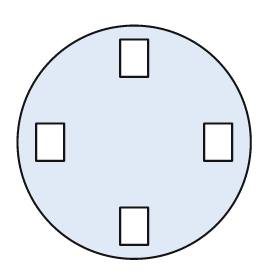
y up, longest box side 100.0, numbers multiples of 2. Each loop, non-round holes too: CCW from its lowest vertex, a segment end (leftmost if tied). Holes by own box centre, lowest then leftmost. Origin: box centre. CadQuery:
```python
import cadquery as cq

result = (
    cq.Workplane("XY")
    .moveTo(0.0, 0.0)
    .circle(50.0)
    .moveTo(-6.0, -44.0)
    .lineTo(6.0, -44.0)
    .lineTo(6.0, -28.0)
    .lineTo(-6.0, -28.0)
    .close()
    .moveTo(-42.0, -8.0)
    .lineTo(-30.0, -8.0)
    .lineTo(-30.0, 8.0)
    .lineTo(-42.0, 8.0)
    .close()
    .moveTo(30.0, -8.0)
    .lineTo(42.0, -8.0)
    .lineTo(42.0, 8.0)
    .lineTo(30.0, 8.0)
    .close()
    .moveTo(-6.0, 28.0)
    .lineTo(6.0, 28.0)
    .lineTo(6.0, 44.0)
    .lineTo(-6.0, 44.0)
    .close()
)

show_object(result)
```